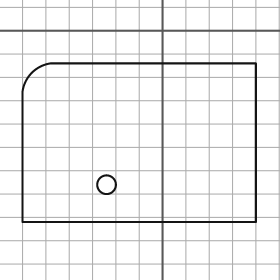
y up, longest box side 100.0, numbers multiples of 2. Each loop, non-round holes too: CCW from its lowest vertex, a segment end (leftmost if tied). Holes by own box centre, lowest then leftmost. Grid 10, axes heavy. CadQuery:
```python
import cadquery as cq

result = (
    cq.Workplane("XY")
    .moveTo(-60.0, -82.0)
    .lineTo(40.0, -82.0)
    .lineTo(40.0, -14.0)
    .lineTo(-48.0, -14.0)
    .threePointArc((-56.0, -18.0), (-60.0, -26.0))
    .close()
    .moveTo(-24.0, -66.0)
    .circle(4.0)
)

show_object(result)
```